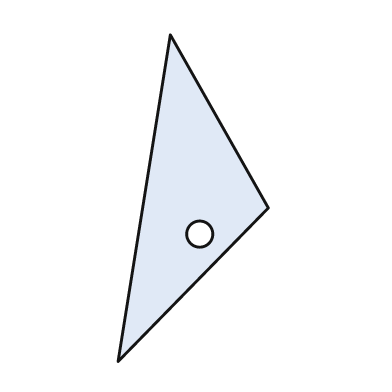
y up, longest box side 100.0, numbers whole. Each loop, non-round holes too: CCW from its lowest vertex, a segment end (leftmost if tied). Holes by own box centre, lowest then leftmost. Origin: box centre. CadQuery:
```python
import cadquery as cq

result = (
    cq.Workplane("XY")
    .moveTo(-23.0, -50.0)
    .lineTo(23.0, -3.0)
    .lineTo(-7.0, 50.0)
    .close()
    .moveTo(2.0, -11.0)
    .circle(4.0)
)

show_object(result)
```